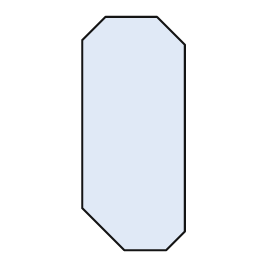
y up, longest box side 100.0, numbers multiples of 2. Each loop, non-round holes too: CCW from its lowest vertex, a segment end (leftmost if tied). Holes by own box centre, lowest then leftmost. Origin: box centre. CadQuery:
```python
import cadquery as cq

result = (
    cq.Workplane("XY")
    .moveTo(-4.0, -50.0)
    .lineTo(14.0, -50.0)
    .lineTo(22.0, -42.0)
    .lineTo(22.0, 38.0)
    .lineTo(10.0, 50.0)
    .lineTo(-12.0, 50.0)
    .lineTo(-22.0, 40.0)
    .lineTo(-22.0, -32.0)
    .close()
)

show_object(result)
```